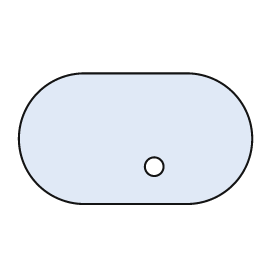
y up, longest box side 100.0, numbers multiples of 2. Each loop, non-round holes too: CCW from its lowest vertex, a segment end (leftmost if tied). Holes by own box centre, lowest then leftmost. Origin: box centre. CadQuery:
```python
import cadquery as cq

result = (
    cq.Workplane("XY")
    .moveTo(-22.0, -28.0)
    .lineTo(22.0, -28.0)
    .threePointArc((50.0, 0.0), (22.0, 28.0))
    .lineTo(-22.0, 28.0)
    .threePointArc((-50.0, 0.0), (-22.0, -28.0))
    .close()
    .moveTo(8.0, -12.0)
    .circle(4.0)
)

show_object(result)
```